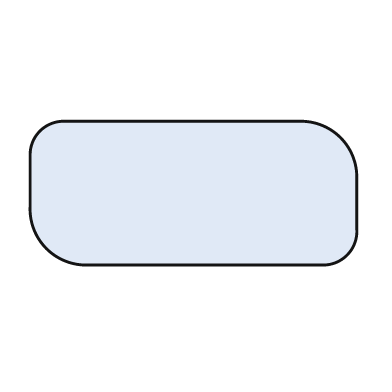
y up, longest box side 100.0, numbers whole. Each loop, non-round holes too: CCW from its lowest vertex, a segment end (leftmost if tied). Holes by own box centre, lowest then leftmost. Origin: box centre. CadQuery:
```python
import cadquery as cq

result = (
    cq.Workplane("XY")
    .moveTo(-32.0, -22.0)
    .lineTo(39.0, -22.0)
    .threePointArc((47.0, -19.0), (50.0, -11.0))
    .lineTo(50.0, 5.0)
    .threePointArc((45.0, 17.0), (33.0, 22.0))
    .lineTo(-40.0, 22.0)
    .threePointArc((-47.0, 19.0), (-50.0, 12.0))
    .lineTo(-50.0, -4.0)
    .threePointArc((-45.0, -17.0), (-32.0, -22.0))
    .close()
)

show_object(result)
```